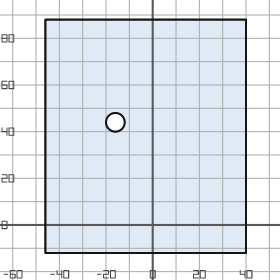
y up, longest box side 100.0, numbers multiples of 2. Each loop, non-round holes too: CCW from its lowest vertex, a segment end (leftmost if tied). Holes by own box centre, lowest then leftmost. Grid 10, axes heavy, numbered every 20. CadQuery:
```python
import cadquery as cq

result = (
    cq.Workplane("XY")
    .moveTo(-46.0, -12.0)
    .lineTo(40.0, -12.0)
    .lineTo(40.0, 88.0)
    .lineTo(-46.0, 88.0)
    .close()
    .moveTo(-16.0, 44.0)
    .circle(4.0)
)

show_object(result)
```